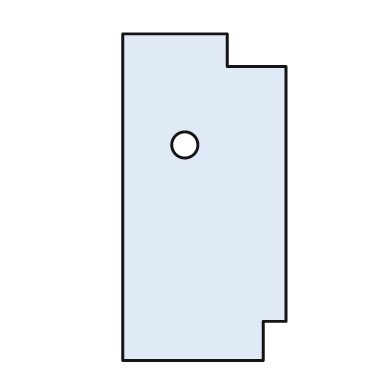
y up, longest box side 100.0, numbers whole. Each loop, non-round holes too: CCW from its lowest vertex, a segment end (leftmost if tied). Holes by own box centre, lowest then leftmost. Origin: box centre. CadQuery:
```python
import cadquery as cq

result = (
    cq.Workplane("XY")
    .moveTo(-25.0, -50.0)
    .lineTo(18.0, -50.0)
    .lineTo(18.0, -38.0)
    .lineTo(25.0, -38.0)
    .lineTo(25.0, 40.0)
    .lineTo(7.0, 40.0)
    .lineTo(7.0, 50.0)
    .lineTo(-25.0, 50.0)
    .close()
    .moveTo(-6.0, 16.0)
    .circle(4.0)
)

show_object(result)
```